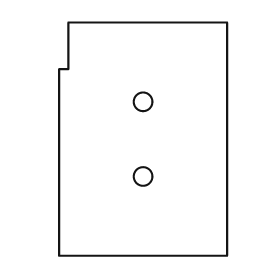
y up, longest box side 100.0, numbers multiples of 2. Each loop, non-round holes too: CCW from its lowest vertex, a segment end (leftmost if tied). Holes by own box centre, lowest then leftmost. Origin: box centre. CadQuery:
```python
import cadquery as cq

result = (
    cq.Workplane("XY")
    .moveTo(-36.0, -50.0)
    .lineTo(36.0, -50.0)
    .lineTo(36.0, 50.0)
    .lineTo(-32.0, 50.0)
    .lineTo(-32.0, 30.0)
    .lineTo(-36.0, 30.0)
    .close()
    .moveTo(0.0, -16.0)
    .circle(4.0)
    .moveTo(0.0, 16.0)
    .circle(4.0)
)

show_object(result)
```